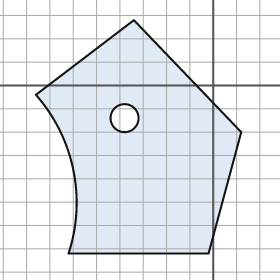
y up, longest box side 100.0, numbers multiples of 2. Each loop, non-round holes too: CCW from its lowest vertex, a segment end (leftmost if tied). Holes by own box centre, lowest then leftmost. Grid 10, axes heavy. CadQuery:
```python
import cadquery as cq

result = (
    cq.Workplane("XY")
    .moveTo(-62.0, -72.0)
    .lineTo(-2.0, -72.0)
    .lineTo(12.0, -20.0)
    .lineTo(-34.0, 28.0)
    .lineTo(-76.0, -4.0)
    .threePointArc((-60.0, -36.0), (-62.0, -72.0))
    .close()
    .moveTo(-38.0, -14.0)
    .circle(6.0)
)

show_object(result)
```